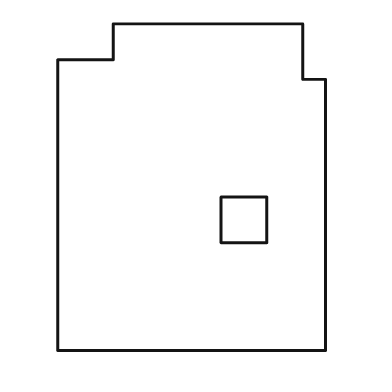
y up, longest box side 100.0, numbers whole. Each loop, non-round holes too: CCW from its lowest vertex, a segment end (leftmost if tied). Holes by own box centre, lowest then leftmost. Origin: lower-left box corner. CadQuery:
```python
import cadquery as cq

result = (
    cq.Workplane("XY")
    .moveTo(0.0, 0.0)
    .lineTo(82.0, 0.0)
    .lineTo(82.0, 83.0)
    .lineTo(75.0, 83.0)
    .lineTo(75.0, 100.0)
    .lineTo(17.0, 100.0)
    .lineTo(17.0, 89.0)
    .lineTo(0.0, 89.0)
    .close()
    .moveTo(50.0, 33.0)
    .lineTo(64.0, 33.0)
    .lineTo(64.0, 47.0)
    .lineTo(50.0, 47.0)
    .close()
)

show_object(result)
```